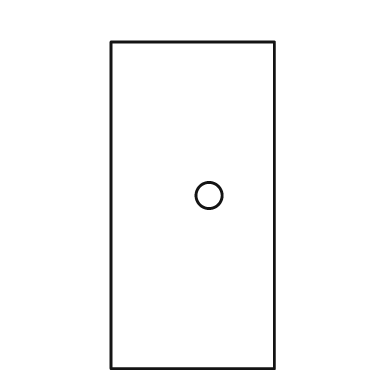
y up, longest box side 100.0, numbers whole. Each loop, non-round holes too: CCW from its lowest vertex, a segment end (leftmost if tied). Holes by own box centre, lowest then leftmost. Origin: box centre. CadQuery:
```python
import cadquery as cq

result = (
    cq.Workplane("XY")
    .moveTo(-25.0, -50.0)
    .lineTo(25.0, -50.0)
    .lineTo(25.0, 50.0)
    .lineTo(-25.0, 50.0)
    .close()
    .moveTo(5.0, 3.0)
    .circle(4.0)
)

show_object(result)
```